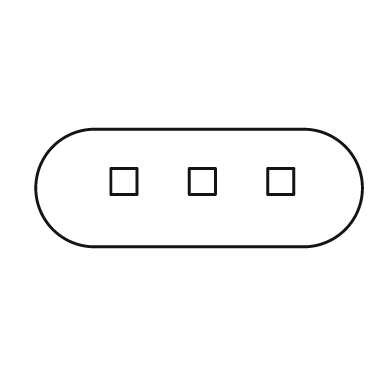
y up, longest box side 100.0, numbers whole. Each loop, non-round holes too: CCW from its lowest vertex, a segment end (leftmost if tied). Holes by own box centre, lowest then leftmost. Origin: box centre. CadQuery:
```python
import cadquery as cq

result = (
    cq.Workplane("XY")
    .moveTo(-32.0, -18.0)
    .lineTo(32.0, -18.0)
    .threePointArc((50.0, 0.0), (32.0, 18.0))
    .lineTo(-32.0, 18.0)
    .threePointArc((-50.0, 0.0), (-32.0, -18.0))
    .close()
    .moveTo(-27.0, -2.0)
    .lineTo(-19.0, -2.0)
    .lineTo(-19.0, 6.0)
    .lineTo(-27.0, 6.0)
    .close()
    .moveTo(-3.0, -2.0)
    .lineTo(5.0, -2.0)
    .lineTo(5.0, 6.0)
    .lineTo(-3.0, 6.0)
    .close()
    .moveTo(21.0, -2.0)
    .lineTo(29.0, -2.0)
    .lineTo(29.0, 6.0)
    .lineTo(21.0, 6.0)
    .close()
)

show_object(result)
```